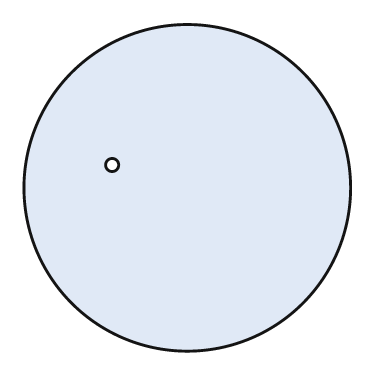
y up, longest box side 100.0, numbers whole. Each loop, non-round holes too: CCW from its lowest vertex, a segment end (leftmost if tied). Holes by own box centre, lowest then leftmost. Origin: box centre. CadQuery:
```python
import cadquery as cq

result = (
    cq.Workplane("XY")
    .moveTo(0.0, 0.0)
    .circle(50.0)
    .moveTo(-23.0, 7.0)
    .circle(2.0)
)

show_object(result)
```